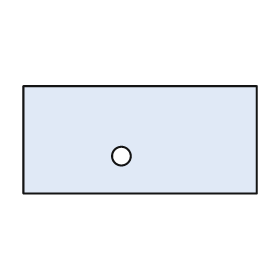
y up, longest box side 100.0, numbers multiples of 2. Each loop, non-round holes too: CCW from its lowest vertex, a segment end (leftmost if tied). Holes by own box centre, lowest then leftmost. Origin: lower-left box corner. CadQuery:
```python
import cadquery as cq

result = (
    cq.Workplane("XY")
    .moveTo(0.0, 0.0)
    .lineTo(100.0, 0.0)
    .lineTo(100.0, 46.0)
    .lineTo(0.0, 46.0)
    .close()
    .moveTo(42.0, 16.0)
    .circle(4.0)
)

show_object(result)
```